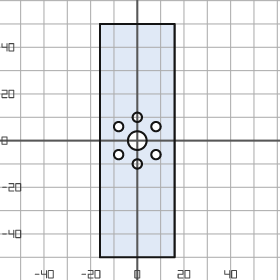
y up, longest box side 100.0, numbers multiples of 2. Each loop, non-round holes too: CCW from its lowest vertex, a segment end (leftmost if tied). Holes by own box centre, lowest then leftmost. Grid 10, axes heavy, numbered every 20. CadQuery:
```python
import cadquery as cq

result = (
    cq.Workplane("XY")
    .moveTo(-16.0, -50.0)
    .lineTo(16.0, -50.0)
    .lineTo(16.0, 50.0)
    .lineTo(-16.0, 50.0)
    .close()
    .moveTo(0.0, -10.0)
    .circle(2.0)
    .moveTo(-8.0, -6.0)
    .circle(2.0)
    .moveTo(8.0, -6.0)
    .circle(2.0)
    .moveTo(0.0, 0.0)
    .circle(4.0)
    .moveTo(-8.0, 6.0)
    .circle(2.0)
    .moveTo(8.0, 6.0)
    .circle(2.0)
    .moveTo(0.0, 10.0)
    .circle(2.0)
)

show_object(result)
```